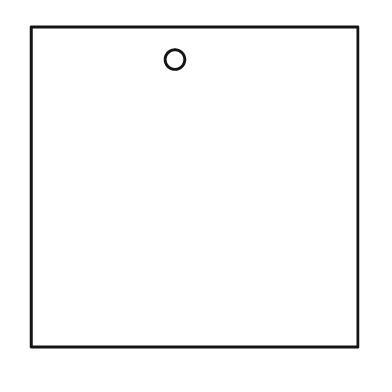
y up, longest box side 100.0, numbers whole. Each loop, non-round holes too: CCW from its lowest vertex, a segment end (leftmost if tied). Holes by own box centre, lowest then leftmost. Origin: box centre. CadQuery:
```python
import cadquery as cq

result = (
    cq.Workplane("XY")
    .moveTo(-50.0, -49.0)
    .lineTo(50.0, -49.0)
    .lineTo(50.0, 49.0)
    .lineTo(-50.0, 49.0)
    .close()
    .moveTo(-6.0, 39.0)
    .circle(3.0)
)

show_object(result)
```